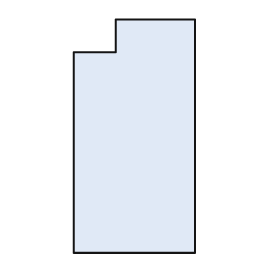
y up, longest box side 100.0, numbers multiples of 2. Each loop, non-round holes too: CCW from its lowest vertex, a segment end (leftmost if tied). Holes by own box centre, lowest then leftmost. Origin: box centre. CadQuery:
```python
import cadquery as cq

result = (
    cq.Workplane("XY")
    .moveTo(-26.0, -50.0)
    .lineTo(26.0, -50.0)
    .lineTo(26.0, 50.0)
    .lineTo(-8.0, 50.0)
    .lineTo(-8.0, 36.0)
    .lineTo(-26.0, 36.0)
    .close()
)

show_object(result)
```